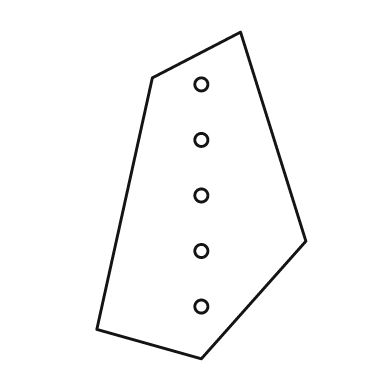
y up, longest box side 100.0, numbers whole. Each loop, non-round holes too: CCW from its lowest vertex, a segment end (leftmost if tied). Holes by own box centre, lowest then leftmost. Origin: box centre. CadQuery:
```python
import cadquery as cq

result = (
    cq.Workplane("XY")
    .moveTo(0.0, -50.0)
    .lineTo(32.0, -14.0)
    .lineTo(12.0, 50.0)
    .lineTo(-15.0, 36.0)
    .lineTo(-32.0, -41.0)
    .close()
    .moveTo(0.0, -34.0)
    .circle(2.0)
    .moveTo(0.0, -17.0)
    .circle(2.0)
    .moveTo(0.0, 0.0)
    .circle(2.0)
    .moveTo(0.0, 17.0)
    .circle(2.0)
    .moveTo(0.0, 34.0)
    .circle(2.0)
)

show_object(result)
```